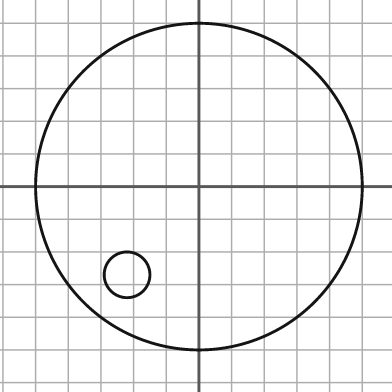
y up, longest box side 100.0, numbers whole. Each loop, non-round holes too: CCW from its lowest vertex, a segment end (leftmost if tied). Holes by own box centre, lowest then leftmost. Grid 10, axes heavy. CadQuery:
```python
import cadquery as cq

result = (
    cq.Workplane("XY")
    .moveTo(0.0, 0.0)
    .circle(50.0)
    .moveTo(-22.0, -27.0)
    .circle(7.0)
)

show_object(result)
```